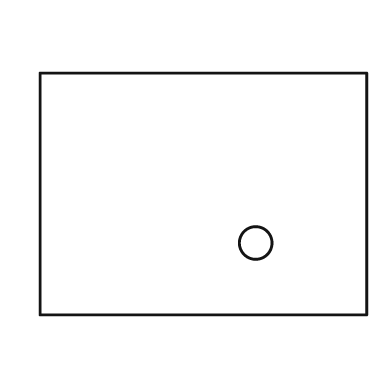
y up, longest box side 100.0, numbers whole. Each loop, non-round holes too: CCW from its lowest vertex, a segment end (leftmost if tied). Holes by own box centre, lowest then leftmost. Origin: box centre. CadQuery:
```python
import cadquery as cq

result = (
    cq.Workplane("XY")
    .moveTo(-50.0, -37.0)
    .lineTo(50.0, -37.0)
    .lineTo(50.0, 37.0)
    .lineTo(-50.0, 37.0)
    .close()
    .moveTo(16.0, -15.0)
    .circle(5.0)
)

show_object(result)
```